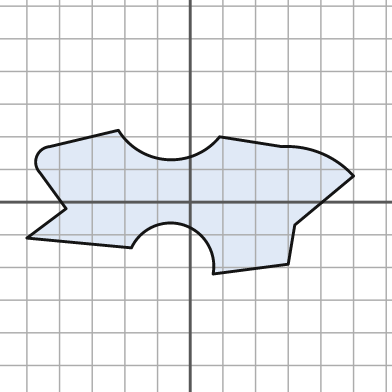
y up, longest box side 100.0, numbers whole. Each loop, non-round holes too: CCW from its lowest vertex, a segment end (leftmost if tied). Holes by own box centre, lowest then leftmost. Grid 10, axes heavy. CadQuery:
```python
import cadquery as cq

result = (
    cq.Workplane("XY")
    .moveTo(7.0, -22.0)
    .lineTo(30.0, -19.0)
    .lineTo(32.0, -7.0)
    .lineTo(50.0, 8.0)
    .threePointArc((40.0, 15.0), (28.0, 17.0))
    .lineTo(9.0, 20.0)
    .threePointArc((-7.0, 13.0), (-22.0, 22.0))
    .lineTo(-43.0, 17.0)
    .threePointArc((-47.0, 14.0), (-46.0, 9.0))
    .lineTo(-38.0, -2.0)
    .lineTo(-50.0, -11.0)
    .lineTo(-18.0, -14.0)
    .threePointArc((-2.0, -7.0), (7.0, -22.0))
    .close()
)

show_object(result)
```